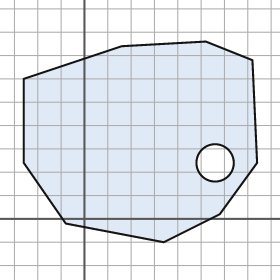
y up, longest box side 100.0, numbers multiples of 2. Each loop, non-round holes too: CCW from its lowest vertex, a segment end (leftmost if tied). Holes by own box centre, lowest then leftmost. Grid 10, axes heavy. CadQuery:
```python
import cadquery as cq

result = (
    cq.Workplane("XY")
    .moveTo(34.0, -10.0)
    .lineTo(58.0, 2.0)
    .lineTo(74.0, 24.0)
    .lineTo(72.0, 68.0)
    .lineTo(52.0, 76.0)
    .lineTo(16.0, 74.0)
    .lineTo(-26.0, 60.0)
    .lineTo(-26.0, 24.0)
    .lineTo(-8.0, -2.0)
    .close()
    .moveTo(56.0, 24.0)
    .circle(8.0)
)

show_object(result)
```